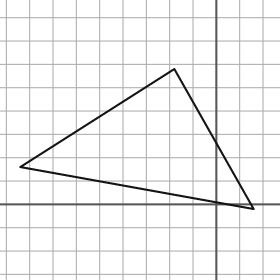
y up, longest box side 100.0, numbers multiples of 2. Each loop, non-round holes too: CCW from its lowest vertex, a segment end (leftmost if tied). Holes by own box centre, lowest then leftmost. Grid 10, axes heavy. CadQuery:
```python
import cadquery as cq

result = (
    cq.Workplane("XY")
    .moveTo(16.0, -2.0)
    .lineTo(-18.0, 58.0)
    .lineTo(-84.0, 16.0)
    .close()
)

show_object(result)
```